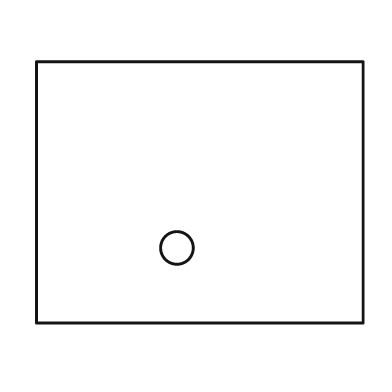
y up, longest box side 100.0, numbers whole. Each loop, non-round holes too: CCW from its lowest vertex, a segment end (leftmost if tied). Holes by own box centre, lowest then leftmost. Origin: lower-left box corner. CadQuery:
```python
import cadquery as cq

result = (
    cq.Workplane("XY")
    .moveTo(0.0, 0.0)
    .lineTo(100.0, 0.0)
    .lineTo(100.0, 80.0)
    .lineTo(0.0, 80.0)
    .close()
    .moveTo(43.0, 23.0)
    .circle(5.0)
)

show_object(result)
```